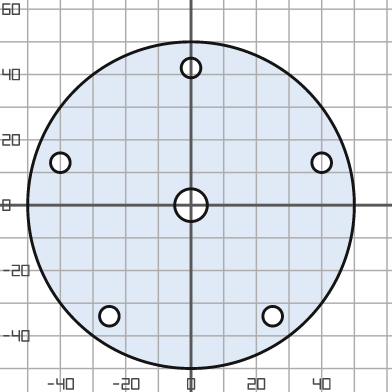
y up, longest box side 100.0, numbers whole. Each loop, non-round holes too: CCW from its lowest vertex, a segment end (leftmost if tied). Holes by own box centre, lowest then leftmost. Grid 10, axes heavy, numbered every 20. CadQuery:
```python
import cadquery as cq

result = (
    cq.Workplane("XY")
    .moveTo(0.0, 0.0)
    .circle(50.0)
    .moveTo(-25.0, -34.0)
    .circle(3.0)
    .moveTo(25.0, -34.0)
    .circle(3.0)
    .moveTo(0.0, 0.0)
    .circle(5.0)
    .moveTo(-40.0, 13.0)
    .circle(3.0)
    .moveTo(40.0, 13.0)
    .circle(3.0)
    .moveTo(0.0, 42.0)
    .circle(3.0)
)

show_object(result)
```